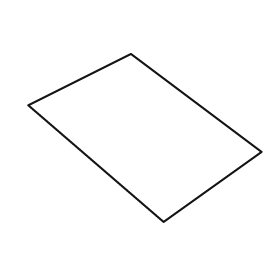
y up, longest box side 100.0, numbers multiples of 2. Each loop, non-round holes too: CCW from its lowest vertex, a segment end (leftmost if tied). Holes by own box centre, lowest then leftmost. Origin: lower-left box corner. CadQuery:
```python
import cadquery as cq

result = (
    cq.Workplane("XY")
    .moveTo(58.0, 0.0)
    .lineTo(100.0, 30.0)
    .lineTo(44.0, 72.0)
    .lineTo(0.0, 50.0)
    .close()
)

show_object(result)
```